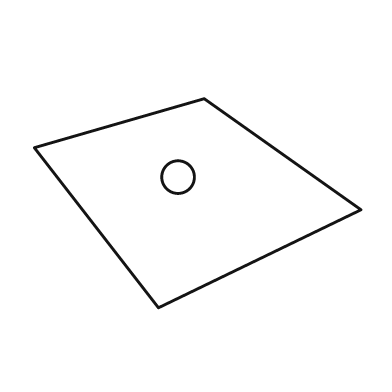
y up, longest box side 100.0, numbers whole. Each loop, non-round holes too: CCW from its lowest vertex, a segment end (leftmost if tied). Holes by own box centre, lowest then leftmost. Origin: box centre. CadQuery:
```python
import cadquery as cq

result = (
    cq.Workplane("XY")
    .moveTo(-12.0, -32.0)
    .lineTo(50.0, -2.0)
    .lineTo(2.0, 32.0)
    .lineTo(-50.0, 17.0)
    .close()
    .moveTo(-6.0, 8.0)
    .circle(5.0)
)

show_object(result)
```